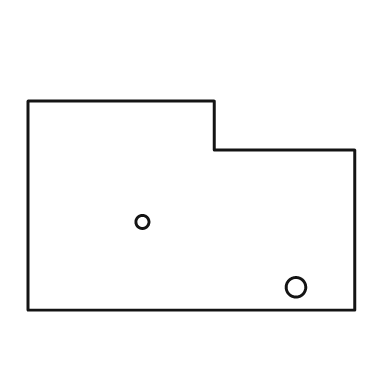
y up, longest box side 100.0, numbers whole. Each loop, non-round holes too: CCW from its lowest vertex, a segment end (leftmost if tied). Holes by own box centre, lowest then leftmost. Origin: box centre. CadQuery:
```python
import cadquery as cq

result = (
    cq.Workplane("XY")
    .moveTo(-50.0, -32.0)
    .lineTo(50.0, -32.0)
    .lineTo(50.0, 17.0)
    .lineTo(7.0, 17.0)
    .lineTo(7.0, 32.0)
    .lineTo(-50.0, 32.0)
    .close()
    .moveTo(32.0, -25.0)
    .circle(3.0)
    .moveTo(-15.0, -5.0)
    .circle(2.0)
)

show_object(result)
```